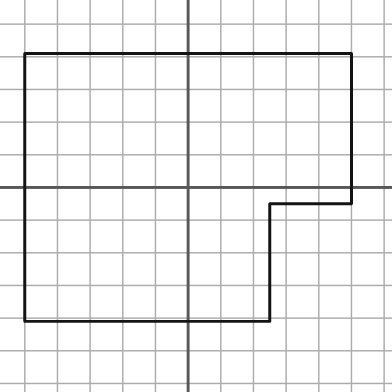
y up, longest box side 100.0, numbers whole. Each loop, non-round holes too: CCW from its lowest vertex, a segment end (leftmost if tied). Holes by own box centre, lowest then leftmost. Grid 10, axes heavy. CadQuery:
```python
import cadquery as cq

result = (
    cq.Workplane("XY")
    .moveTo(-50.0, -41.0)
    .lineTo(25.0, -41.0)
    .lineTo(25.0, -5.0)
    .lineTo(50.0, -5.0)
    .lineTo(50.0, 41.0)
    .lineTo(-50.0, 41.0)
    .close()
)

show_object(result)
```